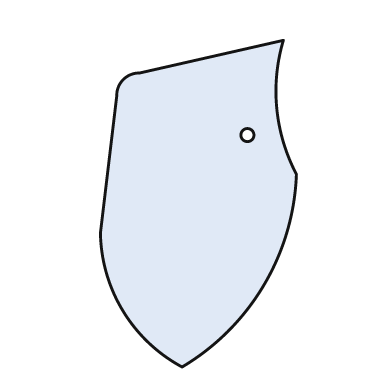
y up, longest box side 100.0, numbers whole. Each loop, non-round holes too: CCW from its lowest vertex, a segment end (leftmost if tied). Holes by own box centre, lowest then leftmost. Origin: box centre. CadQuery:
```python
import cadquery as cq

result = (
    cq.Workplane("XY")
    .moveTo(-5.0, -50.0)
    .threePointArc((20.0, -25.0), (30.0, 9.0))
    .threePointArc((24.0, 29.0), (26.0, 50.0))
    .lineTo(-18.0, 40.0)
    .threePointArc((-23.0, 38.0), (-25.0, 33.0))
    .lineTo(-30.0, -9.0)
    .threePointArc((-23.0, -33.0), (-5.0, -50.0))
    .close()
    .moveTo(15.0, 21.0)
    .circle(2.0)
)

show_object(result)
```